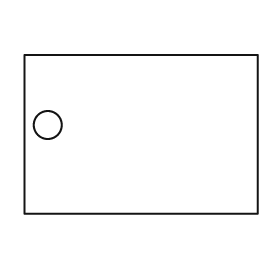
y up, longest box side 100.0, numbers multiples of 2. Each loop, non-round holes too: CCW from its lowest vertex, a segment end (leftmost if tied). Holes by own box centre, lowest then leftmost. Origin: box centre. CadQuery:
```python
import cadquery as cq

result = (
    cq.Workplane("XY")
    .moveTo(-50.0, -34.0)
    .lineTo(50.0, -34.0)
    .lineTo(50.0, 34.0)
    .lineTo(-50.0, 34.0)
    .close()
    .moveTo(-40.0, 4.0)
    .circle(6.0)
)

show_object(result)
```